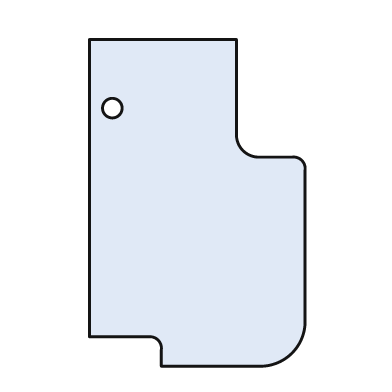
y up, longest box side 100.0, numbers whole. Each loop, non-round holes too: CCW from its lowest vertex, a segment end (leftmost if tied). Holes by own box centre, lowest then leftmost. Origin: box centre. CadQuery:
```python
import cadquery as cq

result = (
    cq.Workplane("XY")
    .moveTo(-11.0, -50.0)
    .lineTo(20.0, -50.0)
    .threePointArc((29.0, -46.0), (33.0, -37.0))
    .lineTo(33.0, 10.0)
    .threePointArc((32.0, 13.0), (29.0, 14.0))
    .lineTo(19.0, 14.0)
    .threePointArc((14.0, 16.0), (12.0, 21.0))
    .lineTo(12.0, 50.0)
    .lineTo(-33.0, 50.0)
    .lineTo(-33.0, -41.0)
    .lineTo(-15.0, -41.0)
    .threePointArc((-12.0, -42.0), (-11.0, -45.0))
    .close()
    .moveTo(-26.0, 29.0)
    .circle(3.0)
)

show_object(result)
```